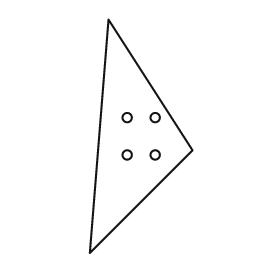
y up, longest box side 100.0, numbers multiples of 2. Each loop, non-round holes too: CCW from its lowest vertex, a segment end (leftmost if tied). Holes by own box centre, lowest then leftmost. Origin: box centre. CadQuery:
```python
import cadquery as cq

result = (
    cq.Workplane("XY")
    .moveTo(-22.0, -50.0)
    .lineTo(22.0, -6.0)
    .lineTo(-14.0, 50.0)
    .close()
    .moveTo(-6.0, -8.0)
    .circle(2.0)
    .moveTo(6.0, -8.0)
    .circle(2.0)
    .moveTo(-6.0, 8.0)
    .circle(2.0)
    .moveTo(6.0, 8.0)
    .circle(2.0)
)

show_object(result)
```